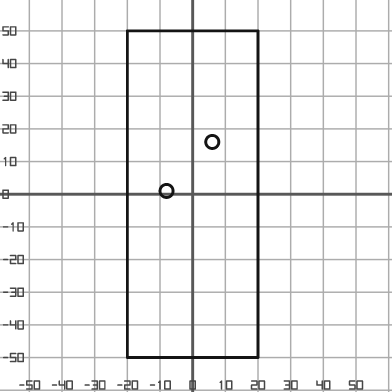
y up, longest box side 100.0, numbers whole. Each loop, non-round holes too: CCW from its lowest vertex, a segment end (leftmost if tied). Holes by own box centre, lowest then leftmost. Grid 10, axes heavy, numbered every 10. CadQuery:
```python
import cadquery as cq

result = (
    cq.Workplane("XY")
    .moveTo(-20.0, -50.0)
    .lineTo(20.0, -50.0)
    .lineTo(20.0, 50.0)
    .lineTo(-20.0, 50.0)
    .close()
    .moveTo(-8.0, 1.0)
    .circle(2.0)
    .moveTo(6.0, 16.0)
    .circle(2.0)
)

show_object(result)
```